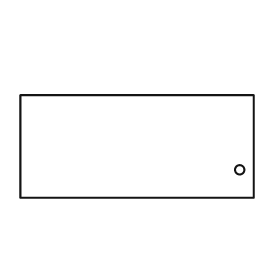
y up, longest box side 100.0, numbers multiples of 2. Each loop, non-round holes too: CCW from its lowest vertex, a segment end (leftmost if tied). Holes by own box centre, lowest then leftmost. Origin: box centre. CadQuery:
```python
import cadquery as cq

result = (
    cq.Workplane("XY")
    .moveTo(-50.0, -22.0)
    .lineTo(50.0, -22.0)
    .lineTo(50.0, 22.0)
    .lineTo(-50.0, 22.0)
    .close()
    .moveTo(44.0, -10.0)
    .circle(2.0)
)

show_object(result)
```